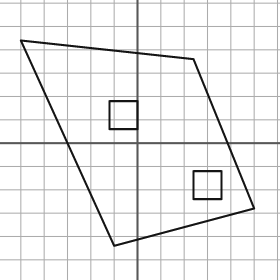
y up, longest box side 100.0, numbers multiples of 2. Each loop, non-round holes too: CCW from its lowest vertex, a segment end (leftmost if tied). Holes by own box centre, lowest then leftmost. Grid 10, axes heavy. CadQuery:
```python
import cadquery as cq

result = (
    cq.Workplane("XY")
    .moveTo(-10.0, -44.0)
    .lineTo(50.0, -28.0)
    .lineTo(24.0, 36.0)
    .lineTo(-50.0, 44.0)
    .close()
    .moveTo(24.0, -24.0)
    .lineTo(36.0, -24.0)
    .lineTo(36.0, -12.0)
    .lineTo(24.0, -12.0)
    .close()
    .moveTo(-12.0, 6.0)
    .lineTo(0.0, 6.0)
    .lineTo(0.0, 18.0)
    .lineTo(-12.0, 18.0)
    .close()
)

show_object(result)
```